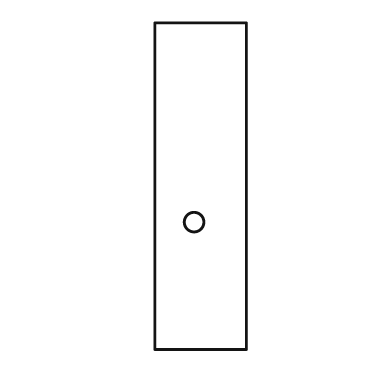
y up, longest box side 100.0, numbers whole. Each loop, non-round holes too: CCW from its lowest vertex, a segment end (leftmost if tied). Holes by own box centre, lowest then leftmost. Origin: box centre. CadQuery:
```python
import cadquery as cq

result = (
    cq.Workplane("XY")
    .moveTo(-14.0, -50.0)
    .lineTo(14.0, -50.0)
    .lineTo(14.0, 50.0)
    .lineTo(-14.0, 50.0)
    .close()
    .moveTo(-2.0, -11.0)
    .circle(3.0)
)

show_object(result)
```